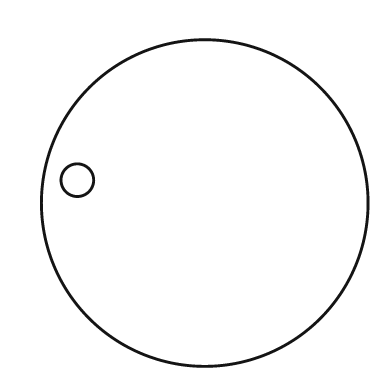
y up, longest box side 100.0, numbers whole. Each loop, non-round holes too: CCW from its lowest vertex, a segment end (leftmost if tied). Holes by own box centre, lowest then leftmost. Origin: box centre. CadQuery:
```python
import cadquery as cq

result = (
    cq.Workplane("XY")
    .moveTo(0.0, 0.0)
    .circle(50.0)
    .moveTo(-39.0, 7.0)
    .circle(5.0)
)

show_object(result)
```